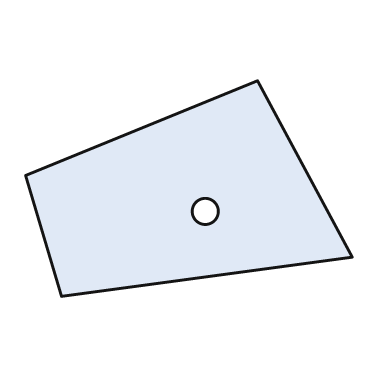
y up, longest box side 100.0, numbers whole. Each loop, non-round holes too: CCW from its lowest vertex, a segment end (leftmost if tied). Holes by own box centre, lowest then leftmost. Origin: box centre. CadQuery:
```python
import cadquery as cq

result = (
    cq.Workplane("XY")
    .moveTo(-39.0, -33.0)
    .lineTo(50.0, -21.0)
    .lineTo(21.0, 33.0)
    .lineTo(-50.0, 4.0)
    .close()
    .moveTo(5.0, -7.0)
    .circle(4.0)
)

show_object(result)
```